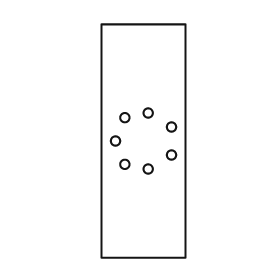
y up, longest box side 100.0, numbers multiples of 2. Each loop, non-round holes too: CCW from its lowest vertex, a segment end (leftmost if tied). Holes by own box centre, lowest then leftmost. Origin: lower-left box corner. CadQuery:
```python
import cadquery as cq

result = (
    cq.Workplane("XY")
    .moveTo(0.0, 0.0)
    .lineTo(36.0, 0.0)
    .lineTo(36.0, 100.0)
    .lineTo(0.0, 100.0)
    .close()
    .moveTo(20.0, 38.0)
    .circle(2.0)
    .moveTo(10.0, 40.0)
    .circle(2.0)
    .moveTo(30.0, 44.0)
    .circle(2.0)
    .moveTo(6.0, 50.0)
    .circle(2.0)
    .moveTo(30.0, 56.0)
    .circle(2.0)
    .moveTo(10.0, 60.0)
    .circle(2.0)
    .moveTo(20.0, 62.0)
    .circle(2.0)
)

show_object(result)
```